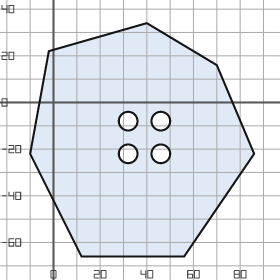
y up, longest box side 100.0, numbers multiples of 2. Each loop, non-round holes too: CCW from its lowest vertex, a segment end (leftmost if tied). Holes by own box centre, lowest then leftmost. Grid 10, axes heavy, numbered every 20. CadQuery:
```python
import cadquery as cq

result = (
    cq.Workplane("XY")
    .moveTo(12.0, -66.0)
    .lineTo(56.0, -66.0)
    .lineTo(86.0, -22.0)
    .lineTo(70.0, 16.0)
    .lineTo(40.0, 34.0)
    .lineTo(-2.0, 22.0)
    .lineTo(-10.0, -22.0)
    .close()
    .moveTo(32.0, -22.0)
    .circle(4.0)
    .moveTo(46.0, -22.0)
    .circle(4.0)
    .moveTo(32.0, -8.0)
    .circle(4.0)
    .moveTo(46.0, -8.0)
    .circle(4.0)
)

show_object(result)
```